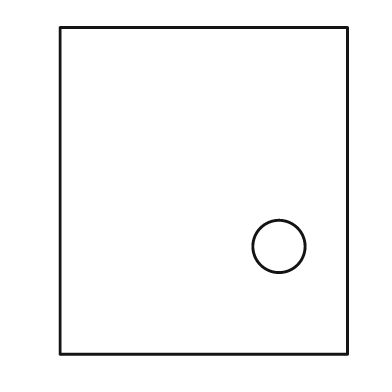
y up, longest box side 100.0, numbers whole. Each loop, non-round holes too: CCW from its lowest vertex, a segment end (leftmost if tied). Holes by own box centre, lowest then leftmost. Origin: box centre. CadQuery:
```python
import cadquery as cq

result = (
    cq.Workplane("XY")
    .moveTo(-44.0, -50.0)
    .lineTo(44.0, -50.0)
    .lineTo(44.0, 50.0)
    .lineTo(-44.0, 50.0)
    .close()
    .moveTo(23.0, -17.0)
    .circle(8.0)
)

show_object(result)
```